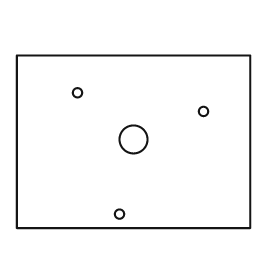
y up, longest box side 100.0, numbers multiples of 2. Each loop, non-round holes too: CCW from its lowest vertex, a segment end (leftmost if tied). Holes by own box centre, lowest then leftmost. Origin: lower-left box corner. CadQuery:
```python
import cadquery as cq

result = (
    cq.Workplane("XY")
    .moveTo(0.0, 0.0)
    .lineTo(100.0, 0.0)
    .lineTo(100.0, 74.0)
    .lineTo(0.0, 74.0)
    .close()
    .moveTo(44.0, 6.0)
    .circle(2.0)
    .moveTo(50.0, 38.0)
    .circle(6.0)
    .moveTo(80.0, 50.0)
    .circle(2.0)
    .moveTo(26.0, 58.0)
    .circle(2.0)
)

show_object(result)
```